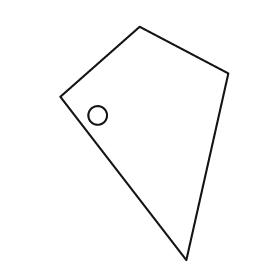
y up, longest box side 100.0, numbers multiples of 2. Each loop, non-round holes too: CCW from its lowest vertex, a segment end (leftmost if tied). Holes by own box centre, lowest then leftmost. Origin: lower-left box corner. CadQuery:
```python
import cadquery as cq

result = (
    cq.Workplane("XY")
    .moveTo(54.0, 0.0)
    .lineTo(72.0, 80.0)
    .lineTo(34.0, 100.0)
    .lineTo(0.0, 70.0)
    .close()
    .moveTo(16.0, 62.0)
    .circle(4.0)
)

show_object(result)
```